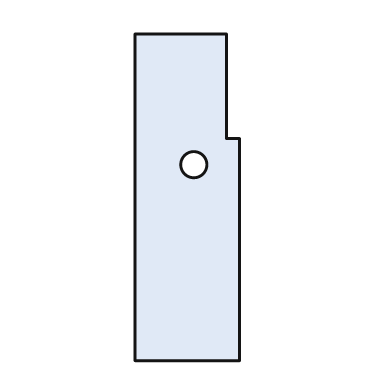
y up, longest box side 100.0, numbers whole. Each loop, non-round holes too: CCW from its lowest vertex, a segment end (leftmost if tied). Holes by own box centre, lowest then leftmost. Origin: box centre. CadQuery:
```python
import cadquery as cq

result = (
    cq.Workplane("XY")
    .moveTo(-16.0, -50.0)
    .lineTo(16.0, -50.0)
    .lineTo(16.0, 18.0)
    .lineTo(12.0, 18.0)
    .lineTo(12.0, 50.0)
    .lineTo(-16.0, 50.0)
    .close()
    .moveTo(2.0, 10.0)
    .circle(4.0)
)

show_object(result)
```